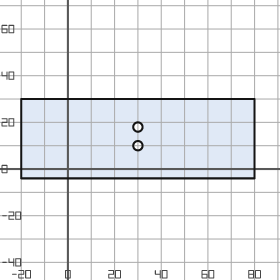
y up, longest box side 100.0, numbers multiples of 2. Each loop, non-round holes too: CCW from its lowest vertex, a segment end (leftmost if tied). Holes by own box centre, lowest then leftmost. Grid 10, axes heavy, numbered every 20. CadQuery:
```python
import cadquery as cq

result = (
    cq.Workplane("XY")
    .moveTo(-20.0, -4.0)
    .lineTo(80.0, -4.0)
    .lineTo(80.0, 30.0)
    .lineTo(-20.0, 30.0)
    .close()
    .moveTo(30.0, 10.0)
    .circle(2.0)
    .moveTo(30.0, 18.0)
    .circle(2.0)
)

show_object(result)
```